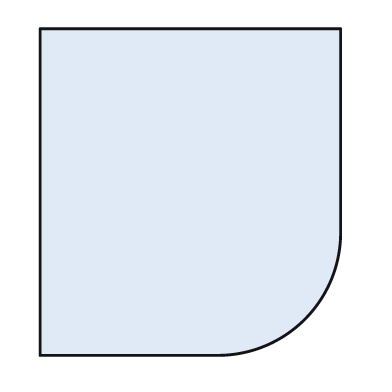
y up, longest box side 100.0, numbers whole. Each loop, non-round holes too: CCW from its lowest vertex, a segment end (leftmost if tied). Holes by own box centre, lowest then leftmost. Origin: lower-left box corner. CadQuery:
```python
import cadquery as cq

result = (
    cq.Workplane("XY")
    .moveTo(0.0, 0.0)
    .lineTo(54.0, 0.0)
    .threePointArc((81.0, 11.0), (92.0, 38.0))
    .lineTo(92.0, 100.0)
    .lineTo(0.0, 100.0)
    .close()
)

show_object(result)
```